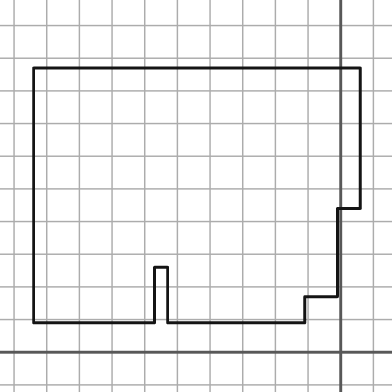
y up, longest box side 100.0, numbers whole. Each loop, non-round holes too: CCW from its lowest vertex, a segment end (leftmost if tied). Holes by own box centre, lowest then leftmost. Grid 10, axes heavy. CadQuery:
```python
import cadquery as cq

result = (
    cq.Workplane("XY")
    .moveTo(-94.0, 9.0)
    .lineTo(-57.0, 9.0)
    .lineTo(-57.0, 26.0)
    .lineTo(-53.0, 26.0)
    .lineTo(-53.0, 9.0)
    .lineTo(-11.0, 9.0)
    .lineTo(-11.0, 17.0)
    .lineTo(-1.0, 17.0)
    .lineTo(-1.0, 44.0)
    .lineTo(6.0, 44.0)
    .lineTo(6.0, 87.0)
    .lineTo(-94.0, 87.0)
    .close()
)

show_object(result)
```